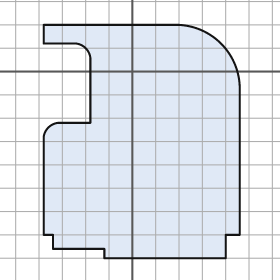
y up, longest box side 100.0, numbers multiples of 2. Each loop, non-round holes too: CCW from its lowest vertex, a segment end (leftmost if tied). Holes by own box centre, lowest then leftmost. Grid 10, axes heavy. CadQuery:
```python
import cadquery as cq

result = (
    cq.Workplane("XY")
    .moveTo(-12.0, -80.0)
    .lineTo(40.0, -80.0)
    .lineTo(40.0, -70.0)
    .lineTo(46.0, -70.0)
    .lineTo(46.0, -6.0)
    .threePointArc((38.0, 12.0), (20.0, 20.0))
    .lineTo(-38.0, 20.0)
    .lineTo(-38.0, 12.0)
    .lineTo(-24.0, 12.0)
    .threePointArc((-20.0, 10.0), (-18.0, 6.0))
    .lineTo(-18.0, -22.0)
    .lineTo(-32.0, -22.0)
    .threePointArc((-36.0, -24.0), (-38.0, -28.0))
    .lineTo(-38.0, -70.0)
    .lineTo(-34.0, -70.0)
    .lineTo(-34.0, -76.0)
    .lineTo(-12.0, -76.0)
    .close()
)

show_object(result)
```